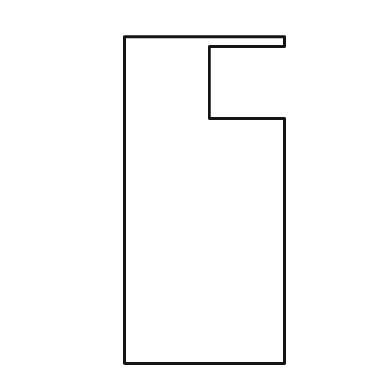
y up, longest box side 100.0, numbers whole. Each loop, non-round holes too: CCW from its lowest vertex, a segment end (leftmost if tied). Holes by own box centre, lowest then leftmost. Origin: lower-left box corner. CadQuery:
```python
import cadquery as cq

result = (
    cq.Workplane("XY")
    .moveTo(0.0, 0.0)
    .lineTo(49.0, 0.0)
    .lineTo(49.0, 75.0)
    .lineTo(26.0, 75.0)
    .lineTo(26.0, 97.0)
    .lineTo(49.0, 97.0)
    .lineTo(49.0, 100.0)
    .lineTo(0.0, 100.0)
    .close()
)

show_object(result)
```